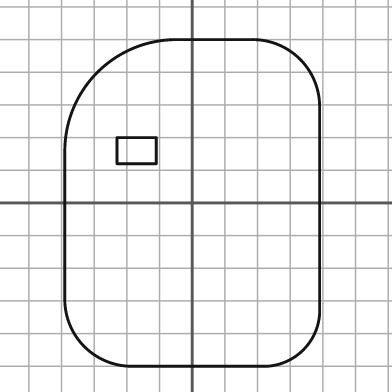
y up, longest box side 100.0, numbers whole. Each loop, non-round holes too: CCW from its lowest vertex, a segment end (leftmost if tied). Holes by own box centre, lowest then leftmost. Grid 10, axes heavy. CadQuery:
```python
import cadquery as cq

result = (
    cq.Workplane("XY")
    .moveTo(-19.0, -50.0)
    .lineTo(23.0, -50.0)
    .threePointArc((34.0, -45.0), (39.0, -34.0))
    .lineTo(39.0, 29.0)
    .threePointArc((33.0, 44.0), (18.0, 50.0))
    .lineTo(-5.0, 50.0)
    .threePointArc((-29.0, 40.0), (-39.0, 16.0))
    .lineTo(-39.0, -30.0)
    .threePointArc((-33.0, -44.0), (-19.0, -50.0))
    .close()
    .moveTo(-23.0, 12.0)
    .lineTo(-11.0, 12.0)
    .lineTo(-11.0, 20.0)
    .lineTo(-23.0, 20.0)
    .close()
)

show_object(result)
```